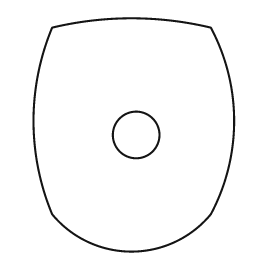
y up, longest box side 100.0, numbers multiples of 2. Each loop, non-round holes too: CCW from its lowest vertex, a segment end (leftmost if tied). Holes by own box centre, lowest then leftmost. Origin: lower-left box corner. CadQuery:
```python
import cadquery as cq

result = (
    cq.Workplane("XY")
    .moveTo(8.0, 16.0)
    .threePointArc((42.0, 0.0), (76.0, 16.0))
    .threePointArc((86.0, 56.0), (76.0, 96.0))
    .threePointArc((42.0, 100.0), (8.0, 96.0))
    .threePointArc((0.0, 56.0), (8.0, 16.0))
    .close()
    .moveTo(44.0, 50.0)
    .circle(10.0)
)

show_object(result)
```